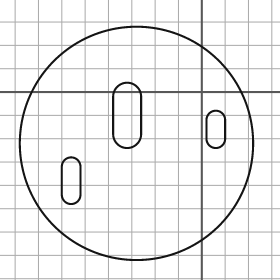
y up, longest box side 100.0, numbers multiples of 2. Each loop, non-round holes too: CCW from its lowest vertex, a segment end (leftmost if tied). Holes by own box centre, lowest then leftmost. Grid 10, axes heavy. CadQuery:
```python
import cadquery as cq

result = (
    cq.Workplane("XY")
    .moveTo(-28.0, -22.0)
    .circle(50.0)
    .moveTo(-60.0, -44.0)
    .threePointArc((-56.0, -48.0), (-52.0, -44.0))
    .lineTo(-52.0, -32.0)
    .threePointArc((-56.0, -28.0), (-60.0, -32.0))
    .close()
    .moveTo(2.0, -20.0)
    .threePointArc((6.0, -24.0), (10.0, -20.0))
    .lineTo(10.0, -12.0)
    .threePointArc((6.0, -8.0), (2.0, -12.0))
    .close()
    .moveTo(-38.0, -18.0)
    .threePointArc((-32.0, -24.0), (-26.0, -18.0))
    .lineTo(-26.0, -2.0)
    .threePointArc((-32.0, 4.0), (-38.0, -2.0))
    .close()
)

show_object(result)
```